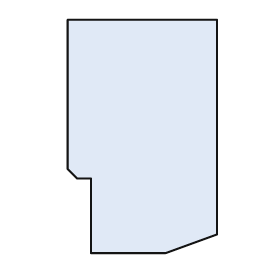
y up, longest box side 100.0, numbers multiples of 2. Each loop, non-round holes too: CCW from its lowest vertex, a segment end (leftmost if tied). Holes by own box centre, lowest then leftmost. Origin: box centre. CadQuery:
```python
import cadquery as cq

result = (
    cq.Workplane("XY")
    .moveTo(-22.0, -50.0)
    .lineTo(10.0, -50.0)
    .lineTo(32.0, -42.0)
    .lineTo(32.0, 50.0)
    .lineTo(-32.0, 50.0)
    .lineTo(-32.0, -14.0)
    .lineTo(-28.0, -18.0)
    .lineTo(-22.0, -18.0)
    .close()
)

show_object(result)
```